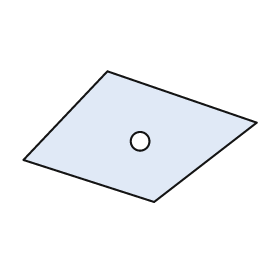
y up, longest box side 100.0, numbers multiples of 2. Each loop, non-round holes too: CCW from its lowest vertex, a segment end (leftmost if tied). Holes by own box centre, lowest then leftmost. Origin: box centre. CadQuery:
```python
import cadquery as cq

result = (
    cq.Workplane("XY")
    .moveTo(6.0, -28.0)
    .lineTo(50.0, 6.0)
    .lineTo(-14.0, 28.0)
    .lineTo(-50.0, -10.0)
    .close()
    .moveTo(0.0, -2.0)
    .circle(4.0)
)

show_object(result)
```